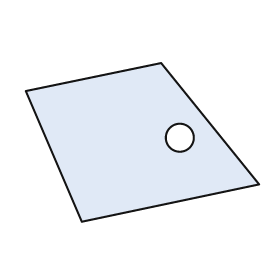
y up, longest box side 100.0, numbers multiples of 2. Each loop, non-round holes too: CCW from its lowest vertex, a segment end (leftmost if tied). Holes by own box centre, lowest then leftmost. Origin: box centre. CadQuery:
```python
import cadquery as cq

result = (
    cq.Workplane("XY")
    .moveTo(-26.0, -34.0)
    .lineTo(50.0, -18.0)
    .lineTo(8.0, 34.0)
    .lineTo(-50.0, 22.0)
    .close()
    .moveTo(16.0, 2.0)
    .circle(6.0)
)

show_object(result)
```